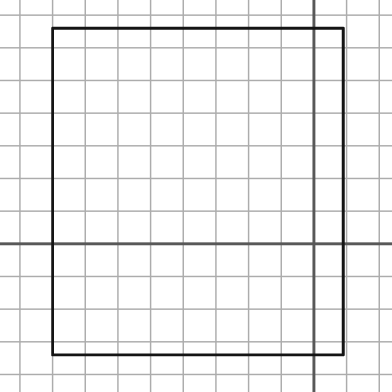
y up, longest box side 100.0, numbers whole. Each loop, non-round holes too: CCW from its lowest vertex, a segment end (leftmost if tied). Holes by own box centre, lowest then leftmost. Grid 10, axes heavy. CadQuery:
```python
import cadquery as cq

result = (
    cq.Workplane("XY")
    .moveTo(-80.0, -34.0)
    .lineTo(9.0, -34.0)
    .lineTo(9.0, 66.0)
    .lineTo(-80.0, 66.0)
    .close()
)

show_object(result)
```